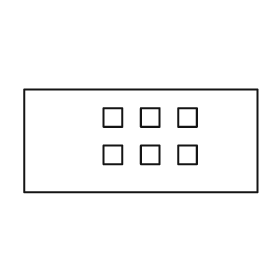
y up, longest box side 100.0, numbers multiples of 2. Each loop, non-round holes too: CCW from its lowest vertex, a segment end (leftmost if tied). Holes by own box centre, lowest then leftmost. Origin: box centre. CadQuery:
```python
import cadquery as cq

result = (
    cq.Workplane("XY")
    .moveTo(-50.0, -22.0)
    .lineTo(50.0, -22.0)
    .lineTo(50.0, 22.0)
    .lineTo(-50.0, 22.0)
    .close()
    .moveTo(-16.0, -10.0)
    .lineTo(-8.0, -10.0)
    .lineTo(-8.0, -2.0)
    .lineTo(-16.0, -2.0)
    .close()
    .moveTo(0.0, -10.0)
    .lineTo(8.0, -10.0)
    .lineTo(8.0, -2.0)
    .lineTo(0.0, -2.0)
    .close()
    .moveTo(16.0, -10.0)
    .lineTo(24.0, -10.0)
    .lineTo(24.0, -2.0)
    .lineTo(16.0, -2.0)
    .close()
    .moveTo(-16.0, 6.0)
    .lineTo(-8.0, 6.0)
    .lineTo(-8.0, 14.0)
    .lineTo(-16.0, 14.0)
    .close()
    .moveTo(0.0, 6.0)
    .lineTo(8.0, 6.0)
    .lineTo(8.0, 14.0)
    .lineTo(0.0, 14.0)
    .close()
    .moveTo(16.0, 6.0)
    .lineTo(24.0, 6.0)
    .lineTo(24.0, 14.0)
    .lineTo(16.0, 14.0)
    .close()
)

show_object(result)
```